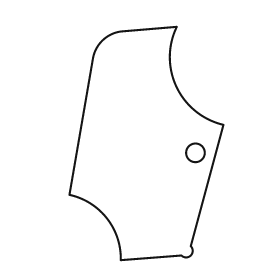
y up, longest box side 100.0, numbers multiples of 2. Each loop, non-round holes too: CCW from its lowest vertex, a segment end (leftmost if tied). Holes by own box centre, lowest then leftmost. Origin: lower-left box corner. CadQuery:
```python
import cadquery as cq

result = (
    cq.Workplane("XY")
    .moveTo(22.0, 0.0)
    .lineTo(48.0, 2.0)
    .threePointArc((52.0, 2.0), (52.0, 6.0))
    .lineTo(66.0, 58.0)
    .threePointArc((46.0, 74.0), (46.0, 100.0))
    .lineTo(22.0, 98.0)
    .threePointArc((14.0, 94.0), (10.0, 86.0))
    .lineTo(0.0, 28.0)
    .threePointArc((16.0, 18.0), (22.0, 0.0))
    .close()
    .moveTo(54.0, 46.0)
    .circle(4.0)
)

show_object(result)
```